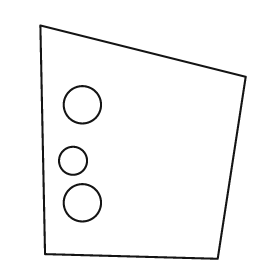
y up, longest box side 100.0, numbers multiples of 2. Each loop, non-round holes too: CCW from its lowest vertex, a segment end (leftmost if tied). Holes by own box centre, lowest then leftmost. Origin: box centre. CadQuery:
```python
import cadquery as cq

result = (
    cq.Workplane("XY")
    .moveTo(32.0, -50.0)
    .lineTo(44.0, 28.0)
    .lineTo(-44.0, 50.0)
    .lineTo(-42.0, -48.0)
    .close()
    .moveTo(-26.0, -26.0)
    .circle(8.0)
    .moveTo(-30.0, -8.0)
    .circle(6.0)
    .moveTo(-26.0, 16.0)
    .circle(8.0)
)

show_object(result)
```